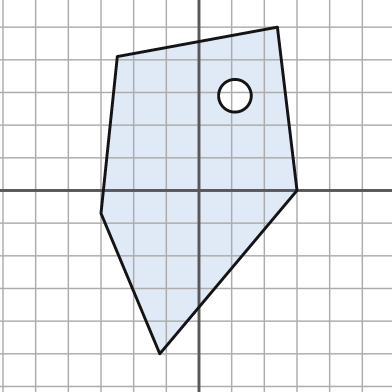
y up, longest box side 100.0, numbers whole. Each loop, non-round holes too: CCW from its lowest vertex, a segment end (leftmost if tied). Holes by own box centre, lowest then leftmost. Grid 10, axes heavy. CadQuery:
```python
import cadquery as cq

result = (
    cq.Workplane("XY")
    .moveTo(-12.0, -50.0)
    .lineTo(30.0, 0.0)
    .lineTo(24.0, 50.0)
    .lineTo(-25.0, 41.0)
    .lineTo(-30.0, -7.0)
    .close()
    .moveTo(11.0, 29.0)
    .circle(5.0)
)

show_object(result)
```